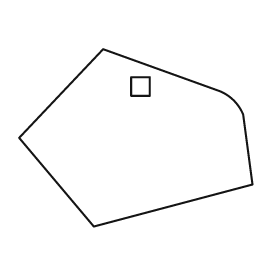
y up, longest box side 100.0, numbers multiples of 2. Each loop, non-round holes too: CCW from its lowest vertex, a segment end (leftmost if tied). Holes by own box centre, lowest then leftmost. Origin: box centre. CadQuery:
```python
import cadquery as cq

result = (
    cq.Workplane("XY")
    .moveTo(-18.0, -38.0)
    .lineTo(50.0, -20.0)
    .lineTo(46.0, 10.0)
    .threePointArc((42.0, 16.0), (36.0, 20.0))
    .lineTo(-14.0, 38.0)
    .lineTo(-50.0, 0.0)
    .close()
    .moveTo(-2.0, 18.0)
    .lineTo(6.0, 18.0)
    .lineTo(6.0, 26.0)
    .lineTo(-2.0, 26.0)
    .close()
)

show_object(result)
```